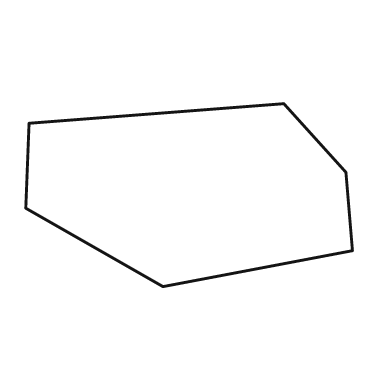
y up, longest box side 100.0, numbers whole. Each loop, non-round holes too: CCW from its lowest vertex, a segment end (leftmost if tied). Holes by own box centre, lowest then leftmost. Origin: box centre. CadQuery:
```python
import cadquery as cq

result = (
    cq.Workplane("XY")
    .moveTo(-8.0, -28.0)
    .lineTo(50.0, -17.0)
    .lineTo(48.0, 7.0)
    .lineTo(29.0, 28.0)
    .lineTo(-49.0, 22.0)
    .lineTo(-50.0, -4.0)
    .close()
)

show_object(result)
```